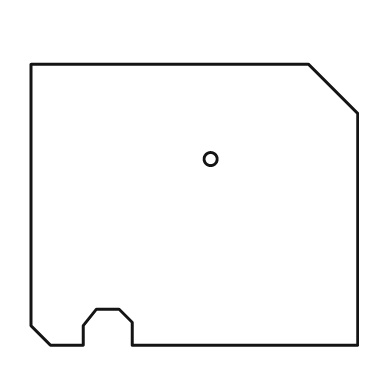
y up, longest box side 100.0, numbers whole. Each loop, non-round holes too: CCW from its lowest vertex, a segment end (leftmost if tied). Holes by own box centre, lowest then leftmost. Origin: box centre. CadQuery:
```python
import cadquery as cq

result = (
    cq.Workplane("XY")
    .moveTo(-44.0, -43.0)
    .lineTo(-34.0, -43.0)
    .lineTo(-34.0, -37.0)
    .lineTo(-30.0, -32.0)
    .lineTo(-23.0, -32.0)
    .lineTo(-19.0, -36.0)
    .lineTo(-19.0, -43.0)
    .lineTo(50.0, -43.0)
    .lineTo(50.0, 28.0)
    .lineTo(35.0, 43.0)
    .lineTo(-50.0, 43.0)
    .lineTo(-50.0, -37.0)
    .close()
    .moveTo(5.0, 14.0)
    .circle(2.0)
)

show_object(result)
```